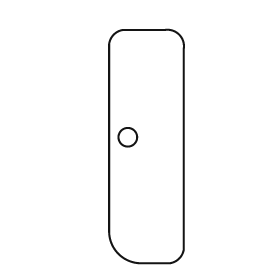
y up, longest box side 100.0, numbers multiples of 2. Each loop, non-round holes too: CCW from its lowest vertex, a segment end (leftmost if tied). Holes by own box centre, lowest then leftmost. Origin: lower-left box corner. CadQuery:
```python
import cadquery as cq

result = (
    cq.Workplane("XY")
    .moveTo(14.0, 0.0)
    .lineTo(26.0, 0.0)
    .threePointArc((30.0, 2.0), (32.0, 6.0))
    .lineTo(32.0, 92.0)
    .threePointArc((30.0, 98.0), (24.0, 100.0))
    .lineTo(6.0, 100.0)
    .threePointArc((2.0, 98.0), (0.0, 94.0))
    .lineTo(0.0, 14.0)
    .threePointArc((4.0, 4.0), (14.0, 0.0))
    .close()
    .moveTo(8.0, 54.0)
    .circle(4.0)
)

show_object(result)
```